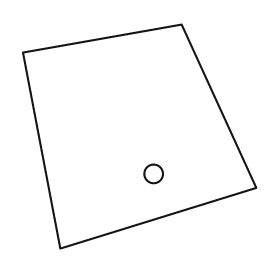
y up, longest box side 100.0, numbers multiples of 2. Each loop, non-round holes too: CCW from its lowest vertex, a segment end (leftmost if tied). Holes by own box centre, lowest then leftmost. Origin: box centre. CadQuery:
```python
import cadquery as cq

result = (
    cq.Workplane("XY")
    .moveTo(-34.0, -48.0)
    .lineTo(50.0, -22.0)
    .lineTo(18.0, 48.0)
    .lineTo(-50.0, 36.0)
    .close()
    .moveTo(6.0, -16.0)
    .circle(4.0)
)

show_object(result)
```